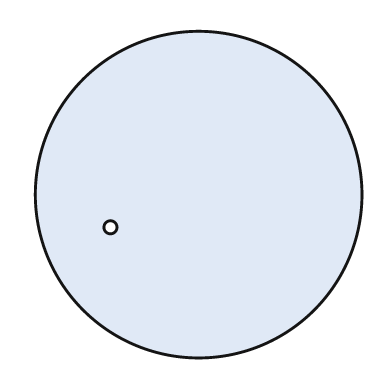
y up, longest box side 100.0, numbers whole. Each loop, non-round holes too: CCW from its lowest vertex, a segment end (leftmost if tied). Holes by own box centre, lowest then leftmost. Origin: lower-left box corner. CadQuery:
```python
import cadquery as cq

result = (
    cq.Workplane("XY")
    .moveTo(50.0, 50.0)
    .circle(50.0)
    .moveTo(23.0, 40.0)
    .circle(2.0)
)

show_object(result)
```